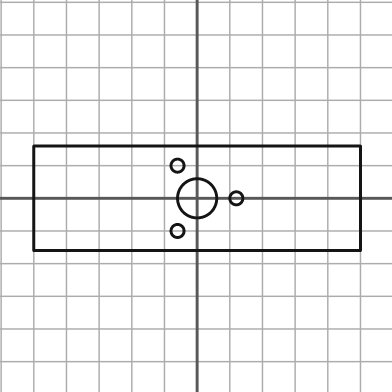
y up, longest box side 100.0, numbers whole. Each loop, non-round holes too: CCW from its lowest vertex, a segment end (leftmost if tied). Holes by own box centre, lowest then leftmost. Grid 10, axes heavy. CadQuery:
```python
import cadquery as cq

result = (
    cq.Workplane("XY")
    .moveTo(-50.0, -16.0)
    .lineTo(50.0, -16.0)
    .lineTo(50.0, 16.0)
    .lineTo(-50.0, 16.0)
    .close()
    .moveTo(-6.0, -10.0)
    .circle(2.0)
    .moveTo(0.0, 0.0)
    .circle(6.0)
    .moveTo(12.0, 0.0)
    .circle(2.0)
    .moveTo(-6.0, 10.0)
    .circle(2.0)
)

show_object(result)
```